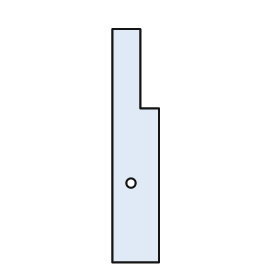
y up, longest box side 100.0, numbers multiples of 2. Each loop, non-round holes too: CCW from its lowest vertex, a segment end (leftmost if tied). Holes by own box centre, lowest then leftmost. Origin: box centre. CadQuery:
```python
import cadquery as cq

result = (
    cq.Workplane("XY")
    .moveTo(-10.0, -50.0)
    .lineTo(10.0, -50.0)
    .lineTo(10.0, 16.0)
    .lineTo(2.0, 16.0)
    .lineTo(2.0, 50.0)
    .lineTo(-10.0, 50.0)
    .close()
    .moveTo(-2.0, -16.0)
    .circle(2.0)
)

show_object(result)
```